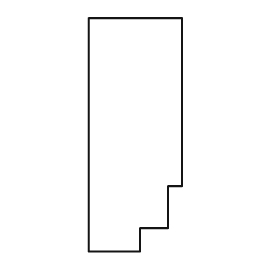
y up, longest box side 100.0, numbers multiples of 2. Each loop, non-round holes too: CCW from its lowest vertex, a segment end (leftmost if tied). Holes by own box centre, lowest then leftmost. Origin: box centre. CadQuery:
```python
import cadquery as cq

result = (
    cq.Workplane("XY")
    .moveTo(-20.0, -50.0)
    .lineTo(2.0, -50.0)
    .lineTo(2.0, -40.0)
    .lineTo(14.0, -40.0)
    .lineTo(14.0, -22.0)
    .lineTo(20.0, -22.0)
    .lineTo(20.0, 50.0)
    .lineTo(-20.0, 50.0)
    .close()
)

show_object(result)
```